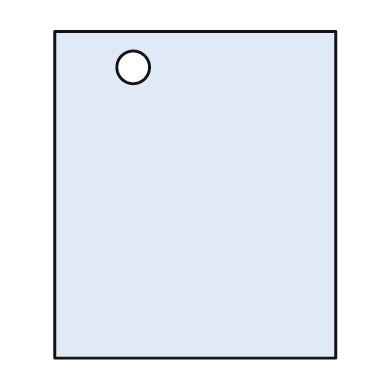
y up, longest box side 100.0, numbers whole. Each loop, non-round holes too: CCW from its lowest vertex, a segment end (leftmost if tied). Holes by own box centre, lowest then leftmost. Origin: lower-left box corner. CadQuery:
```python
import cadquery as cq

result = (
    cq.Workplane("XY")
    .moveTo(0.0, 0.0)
    .lineTo(86.0, 0.0)
    .lineTo(86.0, 100.0)
    .lineTo(0.0, 100.0)
    .close()
    .moveTo(24.0, 89.0)
    .circle(5.0)
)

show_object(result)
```